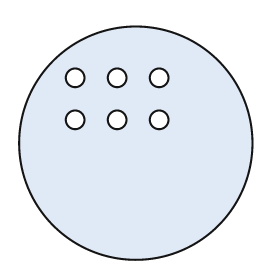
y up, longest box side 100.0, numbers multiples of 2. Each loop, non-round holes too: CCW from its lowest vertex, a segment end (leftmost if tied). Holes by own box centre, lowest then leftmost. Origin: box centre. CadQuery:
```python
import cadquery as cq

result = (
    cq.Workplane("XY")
    .moveTo(0.0, 0.0)
    .circle(50.0)
    .moveTo(-26.0, 10.0)
    .circle(4.0)
    .moveTo(-8.0, 10.0)
    .circle(4.0)
    .moveTo(10.0, 10.0)
    .circle(4.0)
    .moveTo(-26.0, 28.0)
    .circle(4.0)
    .moveTo(-8.0, 28.0)
    .circle(4.0)
    .moveTo(10.0, 28.0)
    .circle(4.0)
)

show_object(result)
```